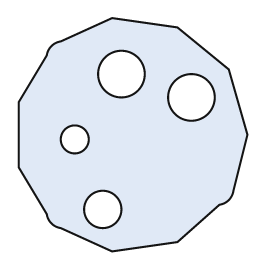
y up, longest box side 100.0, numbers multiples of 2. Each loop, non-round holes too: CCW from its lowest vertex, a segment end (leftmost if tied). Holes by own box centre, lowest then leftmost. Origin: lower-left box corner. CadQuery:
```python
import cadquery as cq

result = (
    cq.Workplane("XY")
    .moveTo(40.0, 0.0)
    .lineTo(68.0, 4.0)
    .lineTo(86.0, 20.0)
    .threePointArc((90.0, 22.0), (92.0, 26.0))
    .lineTo(98.0, 50.0)
    .lineTo(90.0, 78.0)
    .lineTo(68.0, 96.0)
    .lineTo(40.0, 100.0)
    .lineTo(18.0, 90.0)
    .threePointArc((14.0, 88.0), (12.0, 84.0))
    .lineTo(0.0, 64.0)
    .lineTo(0.0, 36.0)
    .lineTo(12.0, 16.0)
    .threePointArc((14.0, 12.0), (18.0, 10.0))
    .close()
    .moveTo(36.0, 18.0)
    .circle(8.0)
    .moveTo(24.0, 48.0)
    .circle(6.0)
    .moveTo(74.0, 66.0)
    .circle(10.0)
    .moveTo(44.0, 76.0)
    .circle(10.0)
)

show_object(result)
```